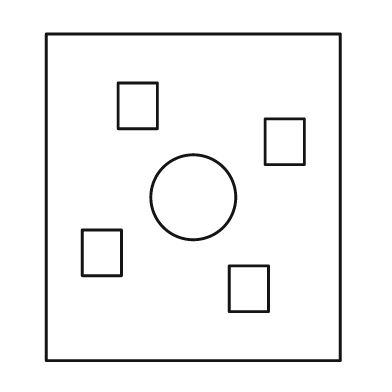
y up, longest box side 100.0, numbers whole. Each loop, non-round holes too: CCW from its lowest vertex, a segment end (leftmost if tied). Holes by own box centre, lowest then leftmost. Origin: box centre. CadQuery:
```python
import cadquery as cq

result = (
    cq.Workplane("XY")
    .moveTo(-45.0, -50.0)
    .lineTo(45.0, -50.0)
    .lineTo(45.0, 50.0)
    .lineTo(-45.0, 50.0)
    .close()
    .moveTo(11.0, -35.0)
    .lineTo(23.0, -35.0)
    .lineTo(23.0, -21.0)
    .lineTo(11.0, -21.0)
    .close()
    .moveTo(-34.0, -24.0)
    .lineTo(-22.0, -24.0)
    .lineTo(-22.0, -10.0)
    .lineTo(-34.0, -10.0)
    .close()
    .moveTo(0.0, 0.0)
    .circle(13.0)
    .moveTo(22.0, 10.0)
    .lineTo(34.0, 10.0)
    .lineTo(34.0, 24.0)
    .lineTo(22.0, 24.0)
    .close()
    .moveTo(-23.0, 21.0)
    .lineTo(-11.0, 21.0)
    .lineTo(-11.0, 35.0)
    .lineTo(-23.0, 35.0)
    .close()
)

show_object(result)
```